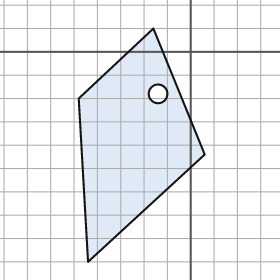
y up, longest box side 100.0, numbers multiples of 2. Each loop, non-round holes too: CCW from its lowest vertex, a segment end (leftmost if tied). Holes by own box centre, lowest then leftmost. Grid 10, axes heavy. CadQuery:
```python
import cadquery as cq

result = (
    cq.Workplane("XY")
    .moveTo(-44.0, -90.0)
    .lineTo(6.0, -44.0)
    .lineTo(-16.0, 10.0)
    .lineTo(-48.0, -20.0)
    .close()
    .moveTo(-14.0, -18.0)
    .circle(4.0)
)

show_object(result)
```